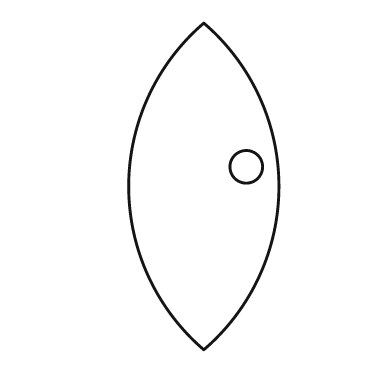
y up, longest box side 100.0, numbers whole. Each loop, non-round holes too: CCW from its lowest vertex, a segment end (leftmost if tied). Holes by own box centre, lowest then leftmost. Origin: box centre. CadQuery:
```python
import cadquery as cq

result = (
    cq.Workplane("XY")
    .moveTo(0.0, -50.0)
    .threePointArc((23.0, 0.0), (0.0, 50.0))
    .threePointArc((-23.0, 0.0), (0.0, -50.0))
    .close()
    .moveTo(13.0, 6.0)
    .circle(5.0)
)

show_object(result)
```